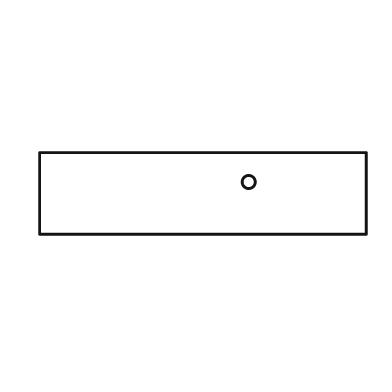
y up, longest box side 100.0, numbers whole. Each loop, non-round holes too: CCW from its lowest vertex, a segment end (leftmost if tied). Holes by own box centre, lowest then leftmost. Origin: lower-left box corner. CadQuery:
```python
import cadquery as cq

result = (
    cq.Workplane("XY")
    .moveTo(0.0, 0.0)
    .lineTo(100.0, 0.0)
    .lineTo(100.0, 25.0)
    .lineTo(0.0, 25.0)
    .close()
    .moveTo(64.0, 16.0)
    .circle(2.0)
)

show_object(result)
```